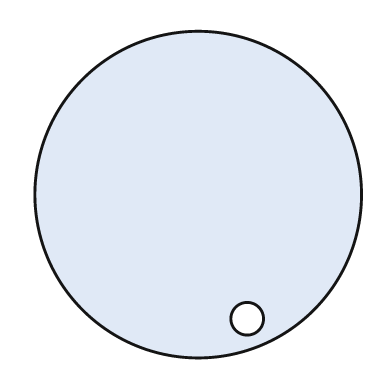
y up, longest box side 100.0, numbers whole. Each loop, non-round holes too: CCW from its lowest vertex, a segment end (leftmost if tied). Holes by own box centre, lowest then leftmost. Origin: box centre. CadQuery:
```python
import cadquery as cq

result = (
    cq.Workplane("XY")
    .moveTo(0.0, 0.0)
    .circle(50.0)
    .moveTo(15.0, -38.0)
    .circle(5.0)
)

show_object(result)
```